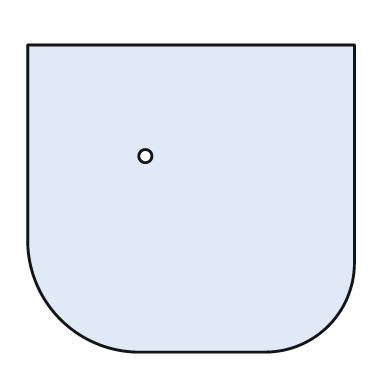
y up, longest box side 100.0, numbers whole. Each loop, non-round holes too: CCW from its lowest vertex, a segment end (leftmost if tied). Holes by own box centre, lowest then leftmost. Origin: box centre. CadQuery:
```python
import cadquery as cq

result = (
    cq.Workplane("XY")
    .moveTo(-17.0, -47.0)
    .lineTo(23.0, -47.0)
    .threePointArc((42.0, -39.0), (50.0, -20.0))
    .lineTo(50.0, 47.0)
    .lineTo(-50.0, 47.0)
    .lineTo(-50.0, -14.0)
    .threePointArc((-40.0, -37.0), (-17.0, -47.0))
    .close()
    .moveTo(-14.0, 13.0)
    .circle(2.0)
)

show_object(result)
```